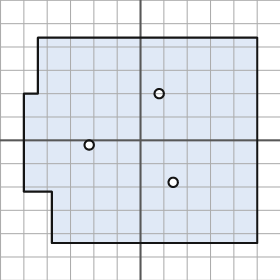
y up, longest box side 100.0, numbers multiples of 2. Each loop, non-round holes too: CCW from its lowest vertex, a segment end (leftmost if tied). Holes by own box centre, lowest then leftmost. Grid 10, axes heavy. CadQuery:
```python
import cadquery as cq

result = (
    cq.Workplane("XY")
    .moveTo(-38.0, -44.0)
    .lineTo(50.0, -44.0)
    .lineTo(50.0, 44.0)
    .lineTo(-44.0, 44.0)
    .lineTo(-44.0, 20.0)
    .lineTo(-50.0, 20.0)
    .lineTo(-50.0, -22.0)
    .lineTo(-38.0, -22.0)
    .close()
    .moveTo(14.0, -18.0)
    .circle(2.0)
    .moveTo(-22.0, -2.0)
    .circle(2.0)
    .moveTo(8.0, 20.0)
    .circle(2.0)
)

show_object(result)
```